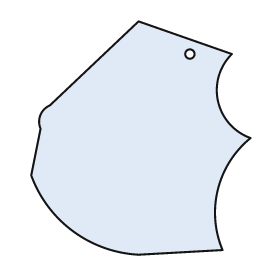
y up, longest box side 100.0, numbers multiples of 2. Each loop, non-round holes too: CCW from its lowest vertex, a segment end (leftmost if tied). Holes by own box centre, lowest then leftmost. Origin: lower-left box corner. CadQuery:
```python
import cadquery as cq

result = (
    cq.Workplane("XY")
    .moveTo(46.0, 0.0)
    .lineTo(82.0, 2.0)
    .threePointArc((80.0, 28.0), (94.0, 50.0))
    .threePointArc((80.0, 66.0), (86.0, 86.0))
    .lineTo(46.0, 100.0)
    .lineTo(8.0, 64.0)
    .threePointArc((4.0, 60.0), (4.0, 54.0))
    .lineTo(0.0, 34.0)
    .threePointArc((18.0, 10.0), (46.0, 0.0))
    .close()
    .moveTo(68.0, 86.0)
    .circle(2.0)
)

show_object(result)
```